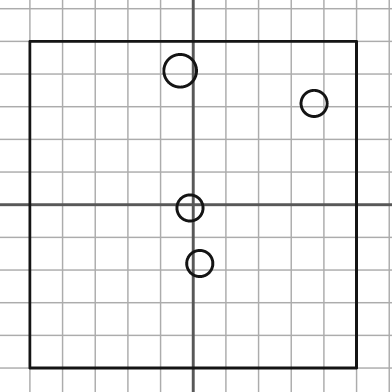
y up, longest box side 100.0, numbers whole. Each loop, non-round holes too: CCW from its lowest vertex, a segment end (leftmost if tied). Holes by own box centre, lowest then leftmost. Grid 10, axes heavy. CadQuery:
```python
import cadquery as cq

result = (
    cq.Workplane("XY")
    .moveTo(-50.0, -50.0)
    .lineTo(50.0, -50.0)
    .lineTo(50.0, 50.0)
    .lineTo(-50.0, 50.0)
    .close()
    .moveTo(2.0, -18.0)
    .circle(4.0)
    .moveTo(-1.0, -1.0)
    .circle(4.0)
    .moveTo(37.0, 31.0)
    .circle(4.0)
    .moveTo(-4.0, 41.0)
    .circle(5.0)
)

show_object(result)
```